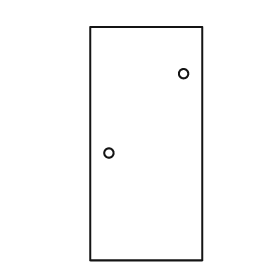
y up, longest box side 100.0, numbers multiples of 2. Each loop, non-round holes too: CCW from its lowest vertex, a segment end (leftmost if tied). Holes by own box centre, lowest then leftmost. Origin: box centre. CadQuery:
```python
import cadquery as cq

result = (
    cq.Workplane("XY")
    .moveTo(-24.0, -50.0)
    .lineTo(24.0, -50.0)
    .lineTo(24.0, 50.0)
    .lineTo(-24.0, 50.0)
    .close()
    .moveTo(-16.0, -4.0)
    .circle(2.0)
    .moveTo(16.0, 30.0)
    .circle(2.0)
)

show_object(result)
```